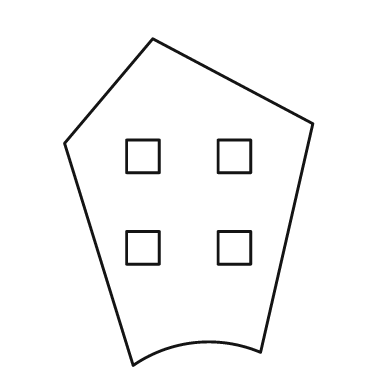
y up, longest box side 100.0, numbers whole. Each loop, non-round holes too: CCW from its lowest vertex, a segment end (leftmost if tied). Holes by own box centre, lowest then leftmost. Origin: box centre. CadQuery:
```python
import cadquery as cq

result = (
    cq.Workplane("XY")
    .moveTo(-17.0, -50.0)
    .threePointArc((2.0, -43.0), (22.0, -46.0))
    .lineTo(38.0, 24.0)
    .lineTo(-11.0, 50.0)
    .lineTo(-38.0, 18.0)
    .close()
    .moveTo(-19.0, -19.0)
    .lineTo(-9.0, -19.0)
    .lineTo(-9.0, -9.0)
    .lineTo(-19.0, -9.0)
    .close()
    .moveTo(9.0, -19.0)
    .lineTo(19.0, -19.0)
    .lineTo(19.0, -9.0)
    .lineTo(9.0, -9.0)
    .close()
    .moveTo(-19.0, 9.0)
    .lineTo(-9.0, 9.0)
    .lineTo(-9.0, 19.0)
    .lineTo(-19.0, 19.0)
    .close()
    .moveTo(9.0, 9.0)
    .lineTo(19.0, 9.0)
    .lineTo(19.0, 19.0)
    .lineTo(9.0, 19.0)
    .close()
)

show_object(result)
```